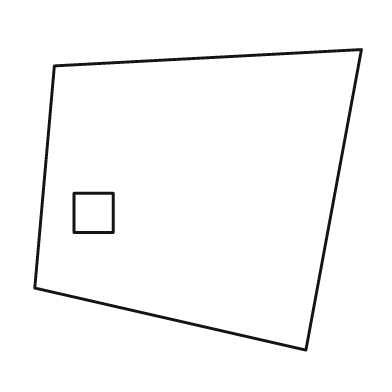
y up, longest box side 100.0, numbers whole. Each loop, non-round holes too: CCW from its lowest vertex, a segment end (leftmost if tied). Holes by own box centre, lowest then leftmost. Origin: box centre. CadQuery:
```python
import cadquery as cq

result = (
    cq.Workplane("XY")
    .moveTo(33.0, -46.0)
    .lineTo(50.0, 46.0)
    .lineTo(-44.0, 41.0)
    .lineTo(-50.0, -27.0)
    .close()
    .moveTo(-38.0, -10.0)
    .lineTo(-26.0, -10.0)
    .lineTo(-26.0, 2.0)
    .lineTo(-38.0, 2.0)
    .close()
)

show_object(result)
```